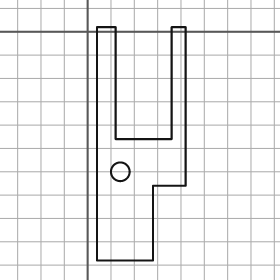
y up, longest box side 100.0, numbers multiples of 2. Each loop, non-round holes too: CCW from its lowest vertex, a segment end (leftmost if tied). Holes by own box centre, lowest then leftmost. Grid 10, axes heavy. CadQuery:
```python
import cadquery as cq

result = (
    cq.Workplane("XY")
    .moveTo(4.0, -98.0)
    .lineTo(28.0, -98.0)
    .lineTo(28.0, -66.0)
    .lineTo(42.0, -66.0)
    .lineTo(42.0, 2.0)
    .lineTo(36.0, 2.0)
    .lineTo(36.0, -46.0)
    .lineTo(12.0, -46.0)
    .lineTo(12.0, 2.0)
    .lineTo(4.0, 2.0)
    .close()
    .moveTo(14.0, -60.0)
    .circle(4.0)
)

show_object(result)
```